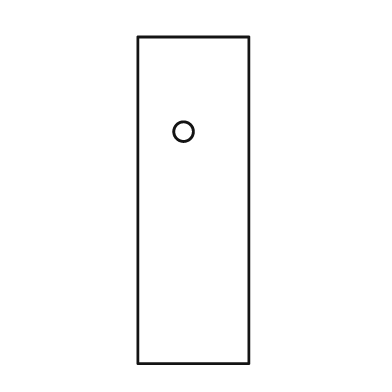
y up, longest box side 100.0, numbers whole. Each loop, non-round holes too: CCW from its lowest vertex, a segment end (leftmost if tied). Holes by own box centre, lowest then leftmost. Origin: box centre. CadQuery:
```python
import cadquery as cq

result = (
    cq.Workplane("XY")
    .moveTo(-17.0, -50.0)
    .lineTo(17.0, -50.0)
    .lineTo(17.0, 50.0)
    .lineTo(-17.0, 50.0)
    .close()
    .moveTo(-3.0, 21.0)
    .circle(3.0)
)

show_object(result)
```